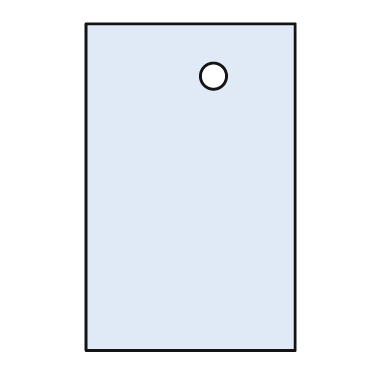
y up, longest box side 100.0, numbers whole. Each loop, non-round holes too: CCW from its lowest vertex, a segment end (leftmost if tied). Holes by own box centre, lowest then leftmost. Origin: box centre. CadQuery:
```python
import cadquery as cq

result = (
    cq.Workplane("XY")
    .moveTo(-32.0, -50.0)
    .lineTo(32.0, -50.0)
    .lineTo(32.0, 50.0)
    .lineTo(-32.0, 50.0)
    .close()
    .moveTo(7.0, 34.0)
    .circle(4.0)
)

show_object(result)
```